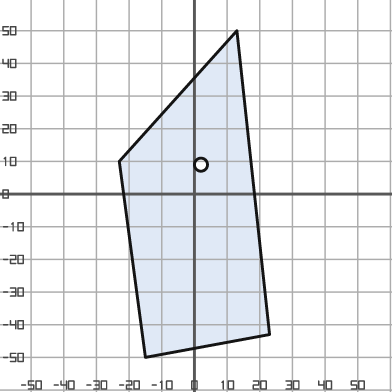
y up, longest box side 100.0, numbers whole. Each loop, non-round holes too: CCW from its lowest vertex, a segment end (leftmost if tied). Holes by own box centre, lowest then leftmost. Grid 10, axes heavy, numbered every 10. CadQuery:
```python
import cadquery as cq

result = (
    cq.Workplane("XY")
    .moveTo(-15.0, -50.0)
    .lineTo(23.0, -43.0)
    .lineTo(13.0, 50.0)
    .lineTo(-23.0, 10.0)
    .close()
    .moveTo(2.0, 9.0)
    .circle(2.0)
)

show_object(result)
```